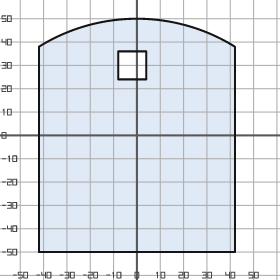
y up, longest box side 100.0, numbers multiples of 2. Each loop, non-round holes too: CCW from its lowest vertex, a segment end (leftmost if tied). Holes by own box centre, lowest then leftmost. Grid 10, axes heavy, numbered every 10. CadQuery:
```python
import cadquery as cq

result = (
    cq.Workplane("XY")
    .moveTo(-42.0, -50.0)
    .lineTo(42.0, -50.0)
    .lineTo(42.0, 38.0)
    .threePointArc((0.0, 50.0), (-42.0, 38.0))
    .close()
    .moveTo(-8.0, 24.0)
    .lineTo(4.0, 24.0)
    .lineTo(4.0, 36.0)
    .lineTo(-8.0, 36.0)
    .close()
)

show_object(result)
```